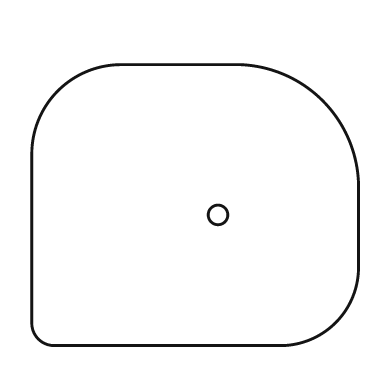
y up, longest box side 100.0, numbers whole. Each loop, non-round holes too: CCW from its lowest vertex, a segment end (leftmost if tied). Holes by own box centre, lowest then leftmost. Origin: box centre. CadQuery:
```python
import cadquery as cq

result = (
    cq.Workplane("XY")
    .moveTo(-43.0, -43.0)
    .lineTo(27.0, -43.0)
    .threePointArc((43.0, -36.0), (50.0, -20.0))
    .lineTo(50.0, 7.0)
    .threePointArc((39.0, 32.0), (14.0, 43.0))
    .lineTo(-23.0, 43.0)
    .threePointArc((-42.0, 35.0), (-50.0, 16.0))
    .lineTo(-50.0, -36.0)
    .threePointArc((-48.0, -41.0), (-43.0, -43.0))
    .close()
    .moveTo(7.0, -3.0)
    .circle(3.0)
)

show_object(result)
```